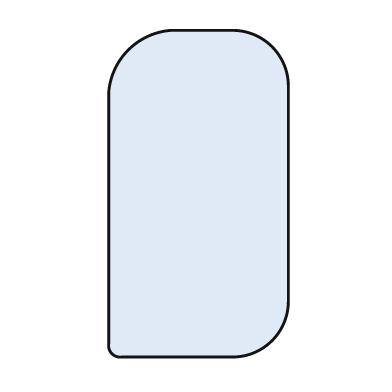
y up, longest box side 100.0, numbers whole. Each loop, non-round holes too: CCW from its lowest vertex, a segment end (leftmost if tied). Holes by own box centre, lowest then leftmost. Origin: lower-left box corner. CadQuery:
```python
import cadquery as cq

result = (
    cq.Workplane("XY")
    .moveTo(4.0, 0.0)
    .lineTo(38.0, 0.0)
    .threePointArc((50.0, 5.0), (55.0, 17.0))
    .lineTo(55.0, 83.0)
    .threePointArc((50.0, 95.0), (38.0, 100.0))
    .lineTo(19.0, 100.0)
    .threePointArc((6.0, 94.0), (0.0, 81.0))
    .lineTo(0.0, 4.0)
    .threePointArc((1.0, 1.0), (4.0, 0.0))
    .close()
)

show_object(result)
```